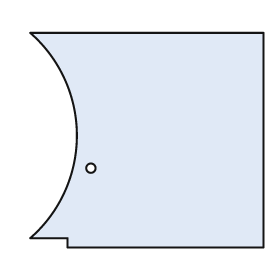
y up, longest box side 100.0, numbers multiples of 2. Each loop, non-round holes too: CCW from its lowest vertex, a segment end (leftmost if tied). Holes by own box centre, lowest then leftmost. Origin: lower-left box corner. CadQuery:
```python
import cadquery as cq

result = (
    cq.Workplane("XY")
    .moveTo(16.0, 0.0)
    .lineTo(100.0, 0.0)
    .lineTo(100.0, 92.0)
    .lineTo(0.0, 92.0)
    .threePointArc((20.0, 48.0), (0.0, 4.0))
    .lineTo(16.0, 4.0)
    .close()
    .moveTo(26.0, 34.0)
    .circle(2.0)
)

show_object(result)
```